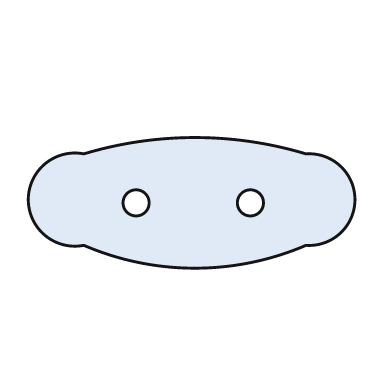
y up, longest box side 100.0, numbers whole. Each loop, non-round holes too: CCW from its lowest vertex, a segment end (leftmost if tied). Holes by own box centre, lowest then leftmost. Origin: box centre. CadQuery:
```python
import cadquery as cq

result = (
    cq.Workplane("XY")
    .moveTo(-33.0, -13.0)
    .threePointArc((1.0, -20.0), (35.0, -13.0))
    .threePointArc((50.0, 1.0), (35.0, 15.0))
    .threePointArc((1.0, 20.0), (-33.0, 15.0))
    .threePointArc((-50.0, 1.0), (-33.0, -13.0))
    .close()
    .moveTo(-17.0, 0.0)
    .circle(4.0)
    .moveTo(18.0, 0.0)
    .circle(4.0)
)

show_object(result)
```